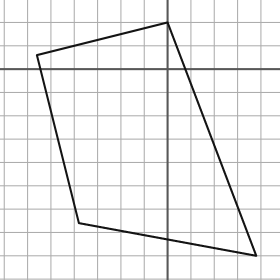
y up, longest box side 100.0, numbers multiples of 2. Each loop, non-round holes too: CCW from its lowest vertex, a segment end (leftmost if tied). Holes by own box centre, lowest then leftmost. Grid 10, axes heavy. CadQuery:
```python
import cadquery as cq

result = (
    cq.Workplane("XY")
    .moveTo(38.0, -80.0)
    .lineTo(0.0, 20.0)
    .lineTo(-56.0, 6.0)
    .lineTo(-38.0, -66.0)
    .close()
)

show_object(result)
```